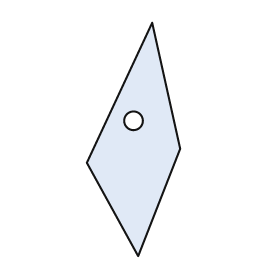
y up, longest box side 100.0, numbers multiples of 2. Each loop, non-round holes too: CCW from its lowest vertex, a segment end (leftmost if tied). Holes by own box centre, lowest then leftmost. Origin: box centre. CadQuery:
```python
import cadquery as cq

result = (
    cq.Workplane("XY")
    .moveTo(2.0, -50.0)
    .lineTo(20.0, -4.0)
    .lineTo(8.0, 50.0)
    .lineTo(-20.0, -10.0)
    .close()
    .moveTo(0.0, 8.0)
    .circle(4.0)
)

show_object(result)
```